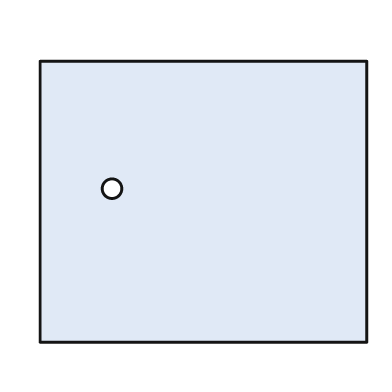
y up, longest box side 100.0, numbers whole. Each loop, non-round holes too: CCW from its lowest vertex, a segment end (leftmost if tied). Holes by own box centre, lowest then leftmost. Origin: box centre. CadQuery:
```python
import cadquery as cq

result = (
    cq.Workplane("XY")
    .moveTo(-50.0, -43.0)
    .lineTo(50.0, -43.0)
    .lineTo(50.0, 43.0)
    .lineTo(-50.0, 43.0)
    .close()
    .moveTo(-28.0, 4.0)
    .circle(3.0)
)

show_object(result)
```